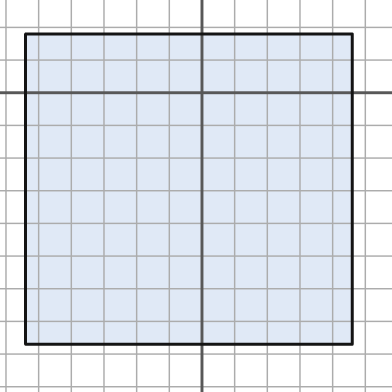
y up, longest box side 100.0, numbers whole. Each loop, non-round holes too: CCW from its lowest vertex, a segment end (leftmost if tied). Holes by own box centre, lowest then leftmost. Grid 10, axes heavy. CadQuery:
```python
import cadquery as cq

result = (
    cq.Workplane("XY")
    .moveTo(-54.0, -77.0)
    .lineTo(46.0, -77.0)
    .lineTo(46.0, 18.0)
    .lineTo(-54.0, 18.0)
    .close()
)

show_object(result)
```